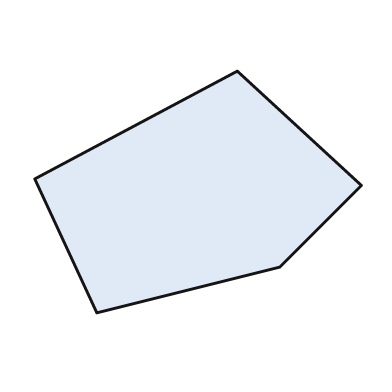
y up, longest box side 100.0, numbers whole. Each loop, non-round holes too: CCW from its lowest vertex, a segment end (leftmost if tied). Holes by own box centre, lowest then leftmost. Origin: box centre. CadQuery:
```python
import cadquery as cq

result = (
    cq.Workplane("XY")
    .moveTo(-31.0, -37.0)
    .lineTo(25.0, -23.0)
    .lineTo(50.0, 2.0)
    .lineTo(12.0, 37.0)
    .lineTo(-50.0, 4.0)
    .close()
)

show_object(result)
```